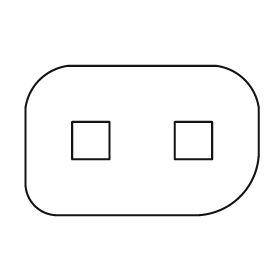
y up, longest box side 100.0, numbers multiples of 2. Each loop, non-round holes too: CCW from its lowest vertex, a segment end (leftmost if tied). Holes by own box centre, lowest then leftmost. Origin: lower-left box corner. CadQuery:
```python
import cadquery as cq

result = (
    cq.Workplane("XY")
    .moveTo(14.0, 0.0)
    .lineTo(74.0, 0.0)
    .threePointArc((92.0, 8.0), (100.0, 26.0))
    .lineTo(100.0, 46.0)
    .threePointArc((94.0, 58.0), (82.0, 64.0))
    .lineTo(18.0, 64.0)
    .threePointArc((6.0, 58.0), (0.0, 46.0))
    .lineTo(0.0, 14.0)
    .threePointArc((4.0, 4.0), (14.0, 0.0))
    .close()
    .moveTo(20.0, 24.0)
    .lineTo(36.0, 24.0)
    .lineTo(36.0, 40.0)
    .lineTo(20.0, 40.0)
    .close()
    .moveTo(64.0, 24.0)
    .lineTo(80.0, 24.0)
    .lineTo(80.0, 40.0)
    .lineTo(64.0, 40.0)
    .close()
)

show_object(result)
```